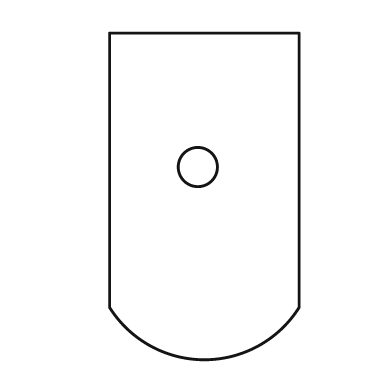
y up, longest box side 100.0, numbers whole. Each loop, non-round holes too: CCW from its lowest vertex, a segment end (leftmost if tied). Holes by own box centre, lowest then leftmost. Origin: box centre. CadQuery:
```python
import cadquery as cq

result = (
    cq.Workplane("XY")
    .moveTo(-29.0, -34.0)
    .threePointArc((0.0, -50.0), (29.0, -34.0))
    .lineTo(29.0, 50.0)
    .lineTo(-29.0, 50.0)
    .close()
    .moveTo(-2.0, 9.0)
    .circle(6.0)
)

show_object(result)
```